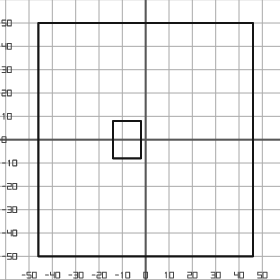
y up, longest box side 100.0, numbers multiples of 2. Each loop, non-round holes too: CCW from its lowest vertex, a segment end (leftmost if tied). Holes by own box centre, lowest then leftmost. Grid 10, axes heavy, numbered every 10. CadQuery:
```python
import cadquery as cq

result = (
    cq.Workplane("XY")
    .moveTo(-46.0, -50.0)
    .lineTo(46.0, -50.0)
    .lineTo(46.0, 50.0)
    .lineTo(-46.0, 50.0)
    .close()
    .moveTo(-14.0, -8.0)
    .lineTo(-2.0, -8.0)
    .lineTo(-2.0, 8.0)
    .lineTo(-14.0, 8.0)
    .close()
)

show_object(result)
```